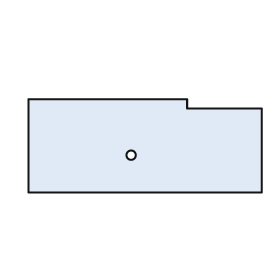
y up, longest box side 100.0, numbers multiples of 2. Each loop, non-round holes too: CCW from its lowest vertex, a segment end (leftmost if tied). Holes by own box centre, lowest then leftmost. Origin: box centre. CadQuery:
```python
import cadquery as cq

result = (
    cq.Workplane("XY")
    .moveTo(-50.0, -20.0)
    .lineTo(50.0, -20.0)
    .lineTo(50.0, 16.0)
    .lineTo(18.0, 16.0)
    .lineTo(18.0, 20.0)
    .lineTo(-50.0, 20.0)
    .close()
    .moveTo(-6.0, -4.0)
    .circle(2.0)
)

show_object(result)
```